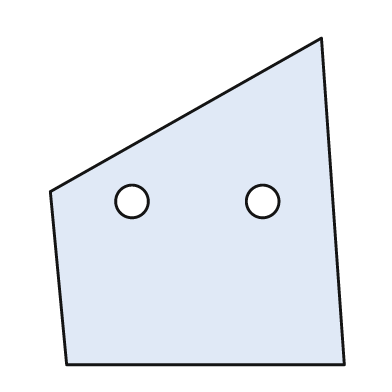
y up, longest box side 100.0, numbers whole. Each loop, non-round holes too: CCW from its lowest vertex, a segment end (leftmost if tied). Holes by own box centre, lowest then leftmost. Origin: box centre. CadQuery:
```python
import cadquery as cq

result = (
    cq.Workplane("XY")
    .moveTo(-40.0, -50.0)
    .lineTo(45.0, -50.0)
    .lineTo(38.0, 50.0)
    .lineTo(-45.0, 3.0)
    .close()
    .moveTo(-20.0, 0.0)
    .circle(5.0)
    .moveTo(20.0, 0.0)
    .circle(5.0)
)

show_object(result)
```